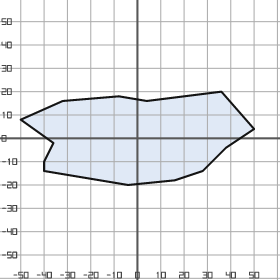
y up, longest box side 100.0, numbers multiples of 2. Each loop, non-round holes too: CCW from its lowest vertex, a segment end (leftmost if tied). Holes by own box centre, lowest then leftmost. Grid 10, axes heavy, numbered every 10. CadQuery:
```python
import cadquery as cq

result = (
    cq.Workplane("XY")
    .moveTo(-4.0, -20.0)
    .lineTo(16.0, -18.0)
    .lineTo(28.0, -14.0)
    .lineTo(38.0, -4.0)
    .lineTo(50.0, 4.0)
    .lineTo(36.0, 20.0)
    .lineTo(4.0, 16.0)
    .lineTo(-8.0, 18.0)
    .lineTo(-32.0, 16.0)
    .lineTo(-50.0, 8.0)
    .lineTo(-36.0, -2.0)
    .lineTo(-40.0, -10.0)
    .lineTo(-40.0, -14.0)
    .close()
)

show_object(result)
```